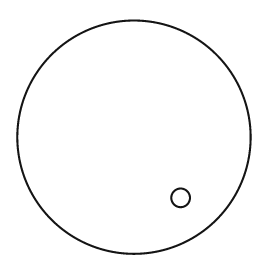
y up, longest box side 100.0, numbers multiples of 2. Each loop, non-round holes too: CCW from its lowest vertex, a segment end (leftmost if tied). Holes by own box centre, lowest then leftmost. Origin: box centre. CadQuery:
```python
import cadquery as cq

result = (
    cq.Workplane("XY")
    .moveTo(0.0, 0.0)
    .circle(50.0)
    .moveTo(20.0, -26.0)
    .circle(4.0)
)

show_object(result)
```